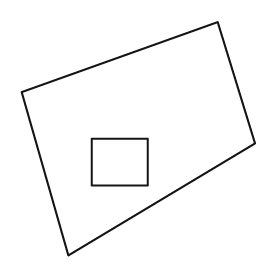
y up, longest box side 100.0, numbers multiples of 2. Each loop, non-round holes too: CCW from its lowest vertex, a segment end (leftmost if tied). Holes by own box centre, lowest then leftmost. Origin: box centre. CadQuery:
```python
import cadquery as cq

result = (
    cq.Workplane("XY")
    .moveTo(-30.0, -50.0)
    .lineTo(50.0, -2.0)
    .lineTo(34.0, 50.0)
    .lineTo(-50.0, 20.0)
    .close()
    .moveTo(-20.0, -20.0)
    .lineTo(4.0, -20.0)
    .lineTo(4.0, 0.0)
    .lineTo(-20.0, 0.0)
    .close()
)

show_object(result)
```